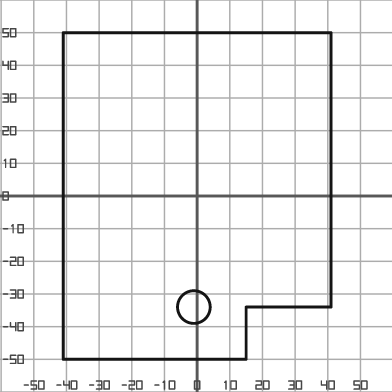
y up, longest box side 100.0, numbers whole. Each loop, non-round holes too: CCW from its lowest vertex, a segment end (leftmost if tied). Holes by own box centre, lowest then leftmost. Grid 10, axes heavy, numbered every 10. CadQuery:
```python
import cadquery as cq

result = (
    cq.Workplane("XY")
    .moveTo(-41.0, -50.0)
    .lineTo(15.0, -50.0)
    .lineTo(15.0, -34.0)
    .lineTo(41.0, -34.0)
    .lineTo(41.0, 50.0)
    .lineTo(-41.0, 50.0)
    .close()
    .moveTo(-1.0, -34.0)
    .circle(5.0)
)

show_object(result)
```